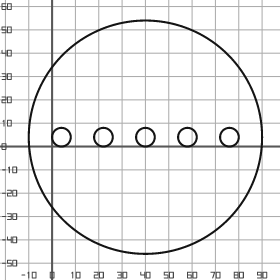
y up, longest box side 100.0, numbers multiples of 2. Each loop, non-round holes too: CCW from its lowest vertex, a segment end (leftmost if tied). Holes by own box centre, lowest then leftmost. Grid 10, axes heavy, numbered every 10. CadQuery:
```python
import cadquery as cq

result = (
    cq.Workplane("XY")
    .moveTo(40.0, 4.0)
    .circle(50.0)
    .moveTo(4.0, 4.0)
    .circle(4.0)
    .moveTo(22.0, 4.0)
    .circle(4.0)
    .moveTo(40.0, 4.0)
    .circle(4.0)
    .moveTo(58.0, 4.0)
    .circle(4.0)
    .moveTo(76.0, 4.0)
    .circle(4.0)
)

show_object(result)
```